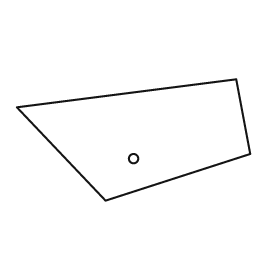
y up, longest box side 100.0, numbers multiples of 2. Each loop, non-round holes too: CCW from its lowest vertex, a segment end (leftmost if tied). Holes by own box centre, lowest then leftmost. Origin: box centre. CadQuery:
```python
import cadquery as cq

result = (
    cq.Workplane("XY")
    .moveTo(-12.0, -26.0)
    .lineTo(50.0, -6.0)
    .lineTo(44.0, 26.0)
    .lineTo(-50.0, 14.0)
    .close()
    .moveTo(0.0, -8.0)
    .circle(2.0)
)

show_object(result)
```